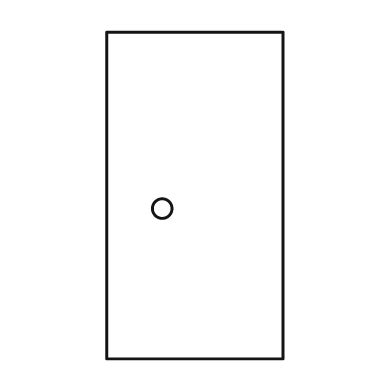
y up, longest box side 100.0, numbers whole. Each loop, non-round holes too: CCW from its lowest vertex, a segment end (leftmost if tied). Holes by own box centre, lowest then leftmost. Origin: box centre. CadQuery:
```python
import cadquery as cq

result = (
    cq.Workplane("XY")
    .moveTo(-27.0, -50.0)
    .lineTo(27.0, -50.0)
    .lineTo(27.0, 50.0)
    .lineTo(-27.0, 50.0)
    .close()
    .moveTo(-10.0, -4.0)
    .circle(3.0)
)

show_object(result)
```